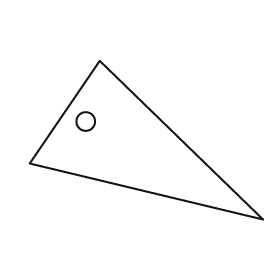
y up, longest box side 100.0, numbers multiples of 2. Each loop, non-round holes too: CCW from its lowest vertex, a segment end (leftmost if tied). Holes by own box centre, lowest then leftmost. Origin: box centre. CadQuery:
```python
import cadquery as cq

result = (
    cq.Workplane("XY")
    .moveTo(50.0, -34.0)
    .lineTo(-20.0, 34.0)
    .lineTo(-50.0, -10.0)
    .close()
    .moveTo(-26.0, 8.0)
    .circle(4.0)
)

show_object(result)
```